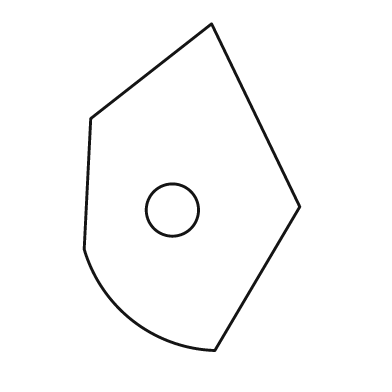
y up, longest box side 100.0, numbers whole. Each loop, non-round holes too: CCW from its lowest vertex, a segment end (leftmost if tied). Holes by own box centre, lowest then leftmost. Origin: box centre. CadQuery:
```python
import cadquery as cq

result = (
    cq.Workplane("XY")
    .moveTo(7.0, -50.0)
    .lineTo(33.0, -6.0)
    .lineTo(6.0, 50.0)
    .lineTo(-31.0, 21.0)
    .lineTo(-33.0, -19.0)
    .threePointArc((-18.0, -41.0), (7.0, -50.0))
    .close()
    .moveTo(-6.0, -7.0)
    .circle(8.0)
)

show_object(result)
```